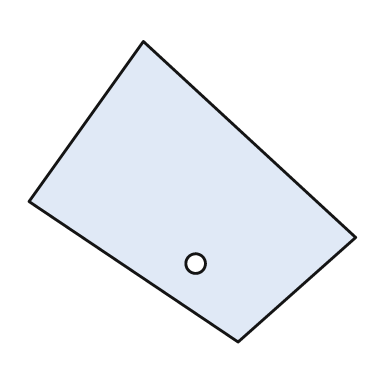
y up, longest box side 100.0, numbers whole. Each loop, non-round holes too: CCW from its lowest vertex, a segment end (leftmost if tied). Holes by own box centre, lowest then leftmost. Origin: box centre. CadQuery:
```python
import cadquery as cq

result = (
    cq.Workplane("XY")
    .moveTo(14.0, -46.0)
    .lineTo(50.0, -14.0)
    .lineTo(-15.0, 46.0)
    .lineTo(-50.0, -3.0)
    .close()
    .moveTo(1.0, -22.0)
    .circle(3.0)
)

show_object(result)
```